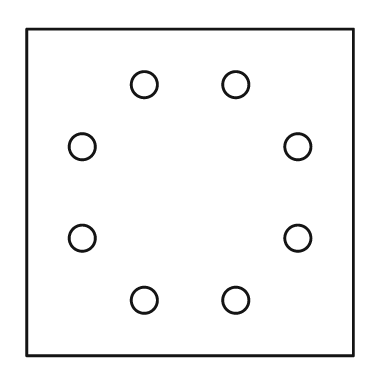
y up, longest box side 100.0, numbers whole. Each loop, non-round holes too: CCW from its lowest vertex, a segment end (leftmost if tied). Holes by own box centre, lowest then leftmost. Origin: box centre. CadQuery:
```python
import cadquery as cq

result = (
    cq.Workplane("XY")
    .moveTo(-50.0, -50.0)
    .lineTo(50.0, -50.0)
    .lineTo(50.0, 50.0)
    .lineTo(-50.0, 50.0)
    .close()
    .moveTo(-14.0, -33.0)
    .circle(4.0)
    .moveTo(14.0, -33.0)
    .circle(4.0)
    .moveTo(-33.0, -14.0)
    .circle(4.0)
    .moveTo(33.0, -14.0)
    .circle(4.0)
    .moveTo(-33.0, 14.0)
    .circle(4.0)
    .moveTo(33.0, 14.0)
    .circle(4.0)
    .moveTo(-14.0, 33.0)
    .circle(4.0)
    .moveTo(14.0, 33.0)
    .circle(4.0)
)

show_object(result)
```